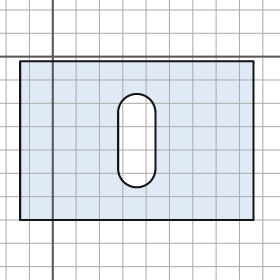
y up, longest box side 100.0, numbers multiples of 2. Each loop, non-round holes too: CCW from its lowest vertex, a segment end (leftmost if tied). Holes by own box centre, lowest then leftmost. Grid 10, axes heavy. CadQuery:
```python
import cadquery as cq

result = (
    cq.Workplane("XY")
    .moveTo(-14.0, -70.0)
    .lineTo(86.0, -70.0)
    .lineTo(86.0, -2.0)
    .lineTo(-14.0, -2.0)
    .close()
    .moveTo(28.0, -48.0)
    .threePointArc((36.0, -56.0), (44.0, -48.0))
    .lineTo(44.0, -24.0)
    .threePointArc((36.0, -16.0), (28.0, -24.0))
    .close()
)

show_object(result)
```